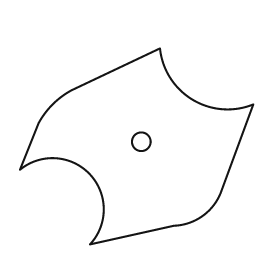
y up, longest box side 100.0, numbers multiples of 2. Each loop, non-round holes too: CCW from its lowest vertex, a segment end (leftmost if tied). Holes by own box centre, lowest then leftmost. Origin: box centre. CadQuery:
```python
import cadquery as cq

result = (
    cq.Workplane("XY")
    .moveTo(-20.0, -42.0)
    .lineTo(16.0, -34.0)
    .threePointArc((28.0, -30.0), (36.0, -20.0))
    .lineTo(50.0, 18.0)
    .threePointArc((24.0, 20.0), (10.0, 42.0))
    .lineTo(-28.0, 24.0)
    .threePointArc((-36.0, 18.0), (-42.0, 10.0))
    .lineTo(-50.0, -10.0)
    .threePointArc((-20.0, -12.0), (-20.0, -42.0))
    .close()
    .moveTo(2.0, 2.0)
    .circle(4.0)
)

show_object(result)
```